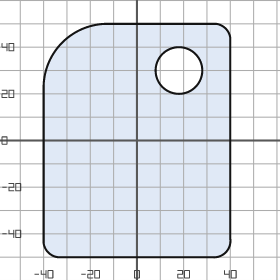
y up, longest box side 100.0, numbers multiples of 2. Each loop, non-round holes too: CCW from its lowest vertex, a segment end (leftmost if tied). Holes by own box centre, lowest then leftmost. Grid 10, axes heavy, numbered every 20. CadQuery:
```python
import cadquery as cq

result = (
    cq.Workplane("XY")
    .moveTo(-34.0, -50.0)
    .lineTo(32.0, -50.0)
    .threePointArc((38.0, -48.0), (40.0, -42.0))
    .lineTo(40.0, 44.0)
    .threePointArc((38.0, 48.0), (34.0, 50.0))
    .lineTo(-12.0, 50.0)
    .threePointArc((-32.0, 42.0), (-40.0, 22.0))
    .lineTo(-40.0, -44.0)
    .threePointArc((-38.0, -48.0), (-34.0, -50.0))
    .close()
    .moveTo(18.0, 30.0)
    .circle(10.0)
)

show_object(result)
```